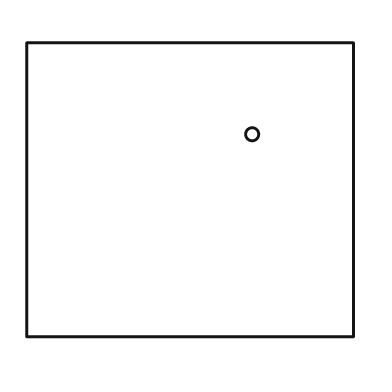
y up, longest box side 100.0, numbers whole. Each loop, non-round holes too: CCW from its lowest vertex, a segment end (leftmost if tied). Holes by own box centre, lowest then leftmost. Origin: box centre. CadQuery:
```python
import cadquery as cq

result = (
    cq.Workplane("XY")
    .moveTo(-50.0, -45.0)
    .lineTo(50.0, -45.0)
    .lineTo(50.0, 45.0)
    .lineTo(-50.0, 45.0)
    .close()
    .moveTo(19.0, 17.0)
    .circle(2.0)
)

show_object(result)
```